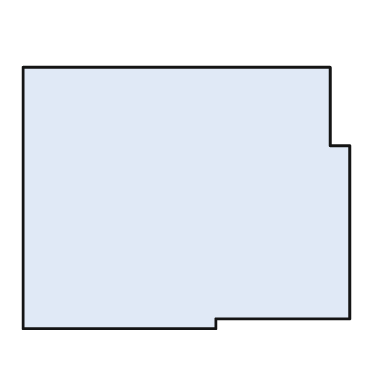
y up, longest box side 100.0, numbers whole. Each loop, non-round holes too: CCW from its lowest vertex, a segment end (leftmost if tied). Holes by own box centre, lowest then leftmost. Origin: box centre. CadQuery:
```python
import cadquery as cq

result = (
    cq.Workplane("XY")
    .moveTo(-50.0, -40.0)
    .lineTo(9.0, -40.0)
    .lineTo(9.0, -37.0)
    .lineTo(50.0, -37.0)
    .lineTo(50.0, 16.0)
    .lineTo(44.0, 16.0)
    .lineTo(44.0, 40.0)
    .lineTo(-50.0, 40.0)
    .close()
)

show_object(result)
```